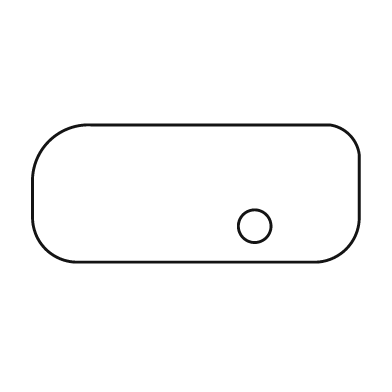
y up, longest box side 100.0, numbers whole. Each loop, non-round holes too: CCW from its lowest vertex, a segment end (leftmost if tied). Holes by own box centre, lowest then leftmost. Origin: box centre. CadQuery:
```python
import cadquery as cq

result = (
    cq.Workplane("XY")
    .moveTo(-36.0, -21.0)
    .lineTo(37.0, -21.0)
    .threePointArc((46.0, -17.0), (50.0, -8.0))
    .lineTo(50.0, 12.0)
    .threePointArc((47.0, 18.0), (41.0, 21.0))
    .lineTo(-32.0, 21.0)
    .threePointArc((-45.0, 16.0), (-50.0, 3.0))
    .lineTo(-50.0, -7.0)
    .threePointArc((-46.0, -17.0), (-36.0, -21.0))
    .close()
    .moveTo(18.0, -10.0)
    .circle(5.0)
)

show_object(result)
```